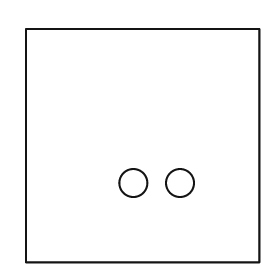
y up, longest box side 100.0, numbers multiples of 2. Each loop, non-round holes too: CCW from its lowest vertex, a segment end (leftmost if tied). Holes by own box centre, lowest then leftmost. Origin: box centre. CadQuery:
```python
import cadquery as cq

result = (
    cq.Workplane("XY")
    .moveTo(-50.0, -50.0)
    .lineTo(50.0, -50.0)
    .lineTo(50.0, 50.0)
    .lineTo(-50.0, 50.0)
    .close()
    .moveTo(-4.0, -16.0)
    .circle(6.0)
    .moveTo(16.0, -16.0)
    .circle(6.0)
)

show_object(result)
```